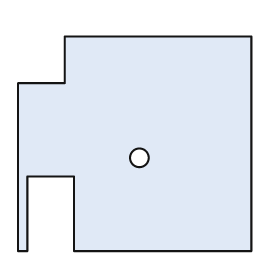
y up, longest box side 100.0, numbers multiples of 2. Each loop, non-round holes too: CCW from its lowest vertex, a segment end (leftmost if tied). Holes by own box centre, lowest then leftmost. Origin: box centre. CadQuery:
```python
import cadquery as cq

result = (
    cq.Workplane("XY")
    .moveTo(-50.0, -46.0)
    .lineTo(-46.0, -46.0)
    .lineTo(-46.0, -14.0)
    .lineTo(-26.0, -14.0)
    .lineTo(-26.0, -46.0)
    .lineTo(50.0, -46.0)
    .lineTo(50.0, 46.0)
    .lineTo(-30.0, 46.0)
    .lineTo(-30.0, 26.0)
    .lineTo(-50.0, 26.0)
    .close()
    .moveTo(2.0, -6.0)
    .circle(4.0)
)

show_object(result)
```